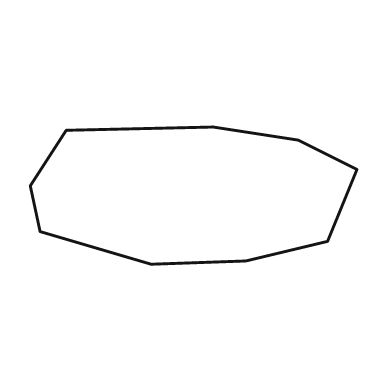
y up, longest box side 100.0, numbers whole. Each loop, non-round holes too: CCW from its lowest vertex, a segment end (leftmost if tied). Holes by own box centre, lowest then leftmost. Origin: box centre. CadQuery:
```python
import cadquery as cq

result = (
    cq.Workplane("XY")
    .moveTo(-13.0, -21.0)
    .lineTo(16.0, -20.0)
    .lineTo(41.0, -14.0)
    .lineTo(50.0, 8.0)
    .lineTo(32.0, 17.0)
    .lineTo(6.0, 21.0)
    .lineTo(-39.0, 20.0)
    .lineTo(-50.0, 3.0)
    .lineTo(-47.0, -11.0)
    .close()
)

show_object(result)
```